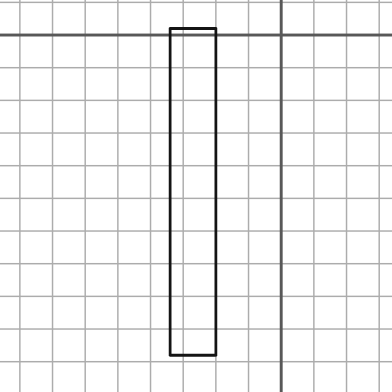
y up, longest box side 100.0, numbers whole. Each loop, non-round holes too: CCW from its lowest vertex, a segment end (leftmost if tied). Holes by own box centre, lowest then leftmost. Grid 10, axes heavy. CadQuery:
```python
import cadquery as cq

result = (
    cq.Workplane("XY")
    .moveTo(-34.0, -98.0)
    .lineTo(-20.0, -98.0)
    .lineTo(-20.0, 2.0)
    .lineTo(-34.0, 2.0)
    .close()
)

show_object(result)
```